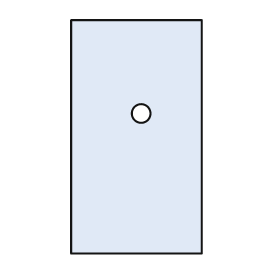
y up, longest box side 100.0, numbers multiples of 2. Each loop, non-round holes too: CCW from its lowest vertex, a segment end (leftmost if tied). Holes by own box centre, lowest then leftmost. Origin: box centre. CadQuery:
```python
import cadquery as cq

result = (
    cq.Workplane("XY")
    .moveTo(-28.0, -50.0)
    .lineTo(28.0, -50.0)
    .lineTo(28.0, 50.0)
    .lineTo(-28.0, 50.0)
    .close()
    .moveTo(2.0, 10.0)
    .circle(4.0)
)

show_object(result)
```